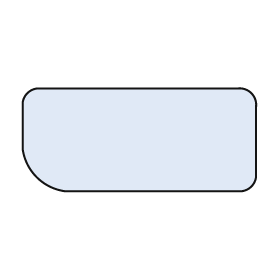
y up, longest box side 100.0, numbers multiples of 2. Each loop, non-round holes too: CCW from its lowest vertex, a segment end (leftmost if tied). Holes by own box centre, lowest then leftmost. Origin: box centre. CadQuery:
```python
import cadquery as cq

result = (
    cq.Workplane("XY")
    .moveTo(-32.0, -22.0)
    .lineTo(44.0, -22.0)
    .threePointArc((48.0, -20.0), (50.0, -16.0))
    .lineTo(50.0, 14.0)
    .threePointArc((48.0, 20.0), (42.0, 22.0))
    .lineTo(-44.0, 22.0)
    .threePointArc((-48.0, 20.0), (-50.0, 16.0))
    .lineTo(-50.0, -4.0)
    .threePointArc((-44.0, -16.0), (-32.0, -22.0))
    .close()
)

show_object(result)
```